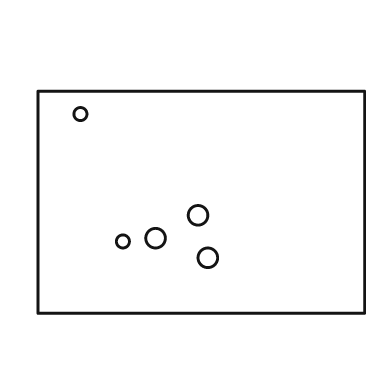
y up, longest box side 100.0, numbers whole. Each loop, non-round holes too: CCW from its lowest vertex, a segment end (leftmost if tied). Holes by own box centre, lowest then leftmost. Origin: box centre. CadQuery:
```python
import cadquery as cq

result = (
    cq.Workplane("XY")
    .moveTo(-50.0, -34.0)
    .lineTo(50.0, -34.0)
    .lineTo(50.0, 34.0)
    .lineTo(-50.0, 34.0)
    .close()
    .moveTo(2.0, -17.0)
    .circle(3.0)
    .moveTo(-24.0, -12.0)
    .circle(2.0)
    .moveTo(-14.0, -11.0)
    .circle(3.0)
    .moveTo(-1.0, -4.0)
    .circle(3.0)
    .moveTo(-37.0, 27.0)
    .circle(2.0)
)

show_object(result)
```